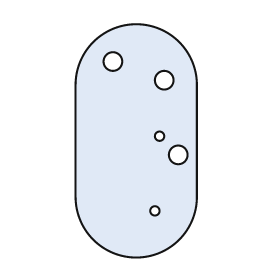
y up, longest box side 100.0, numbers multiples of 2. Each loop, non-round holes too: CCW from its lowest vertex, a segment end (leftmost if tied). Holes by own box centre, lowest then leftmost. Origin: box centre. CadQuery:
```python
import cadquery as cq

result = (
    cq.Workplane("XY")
    .moveTo(-26.0, -24.0)
    .threePointArc((0.0, -50.0), (26.0, -24.0))
    .lineTo(26.0, 24.0)
    .threePointArc((0.0, 50.0), (-26.0, 24.0))
    .close()
    .moveTo(8.0, -30.0)
    .circle(2.0)
    .moveTo(18.0, -6.0)
    .circle(4.0)
    .moveTo(10.0, 2.0)
    .circle(2.0)
    .moveTo(12.0, 26.0)
    .circle(4.0)
    .moveTo(-10.0, 34.0)
    .circle(4.0)
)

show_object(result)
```